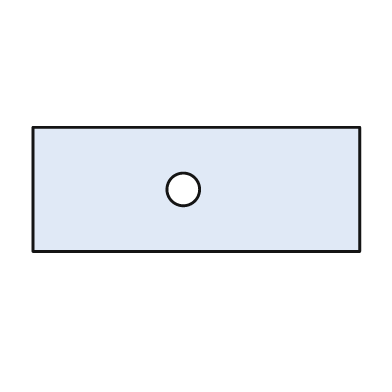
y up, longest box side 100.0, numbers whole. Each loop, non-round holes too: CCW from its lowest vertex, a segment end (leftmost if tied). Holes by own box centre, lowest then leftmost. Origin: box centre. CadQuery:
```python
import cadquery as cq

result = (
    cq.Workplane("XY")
    .moveTo(-50.0, -19.0)
    .lineTo(50.0, -19.0)
    .lineTo(50.0, 19.0)
    .lineTo(-50.0, 19.0)
    .close()
    .moveTo(-4.0, 0.0)
    .circle(5.0)
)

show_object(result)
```